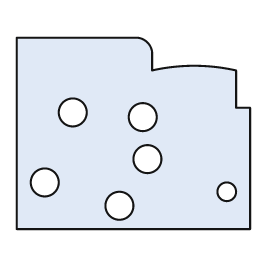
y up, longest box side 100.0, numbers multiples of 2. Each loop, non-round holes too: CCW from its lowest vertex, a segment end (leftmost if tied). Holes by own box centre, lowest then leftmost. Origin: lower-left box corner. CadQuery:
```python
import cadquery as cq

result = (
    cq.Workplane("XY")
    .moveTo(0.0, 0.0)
    .lineTo(100.0, 0.0)
    .lineTo(100.0, 52.0)
    .lineTo(94.0, 52.0)
    .lineTo(94.0, 68.0)
    .threePointArc((76.0, 70.0), (58.0, 68.0))
    .lineTo(58.0, 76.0)
    .threePointArc((56.0, 80.0), (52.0, 82.0))
    .lineTo(0.0, 82.0)
    .close()
    .moveTo(44.0, 10.0)
    .circle(6.0)
    .moveTo(90.0, 16.0)
    .circle(4.0)
    .moveTo(12.0, 20.0)
    .circle(6.0)
    .moveTo(56.0, 30.0)
    .circle(6.0)
    .moveTo(54.0, 48.0)
    .circle(6.0)
    .moveTo(24.0, 50.0)
    .circle(6.0)
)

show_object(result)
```